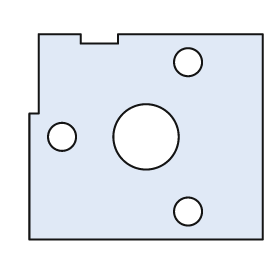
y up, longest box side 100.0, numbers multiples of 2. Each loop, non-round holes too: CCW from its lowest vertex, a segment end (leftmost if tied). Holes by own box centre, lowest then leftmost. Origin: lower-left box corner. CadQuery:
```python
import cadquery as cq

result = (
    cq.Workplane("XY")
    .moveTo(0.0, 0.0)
    .lineTo(100.0, 0.0)
    .lineTo(100.0, 88.0)
    .lineTo(38.0, 88.0)
    .lineTo(38.0, 84.0)
    .lineTo(22.0, 84.0)
    .lineTo(22.0, 88.0)
    .lineTo(4.0, 88.0)
    .lineTo(4.0, 54.0)
    .lineTo(0.0, 54.0)
    .close()
    .moveTo(68.0, 12.0)
    .circle(6.0)
    .moveTo(14.0, 44.0)
    .circle(6.0)
    .moveTo(50.0, 44.0)
    .circle(14.0)
    .moveTo(68.0, 76.0)
    .circle(6.0)
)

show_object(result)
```